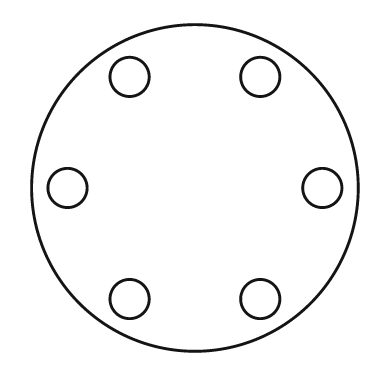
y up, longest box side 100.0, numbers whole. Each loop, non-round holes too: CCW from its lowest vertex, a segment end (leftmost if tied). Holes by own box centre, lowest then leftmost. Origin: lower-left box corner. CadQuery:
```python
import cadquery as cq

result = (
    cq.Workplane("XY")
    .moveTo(50.0, 50.0)
    .circle(50.0)
    .moveTo(30.0, 16.0)
    .circle(6.0)
    .moveTo(70.0, 16.0)
    .circle(6.0)
    .moveTo(11.0, 50.0)
    .circle(6.0)
    .moveTo(89.0, 50.0)
    .circle(6.0)
    .moveTo(30.0, 84.0)
    .circle(6.0)
    .moveTo(70.0, 84.0)
    .circle(6.0)
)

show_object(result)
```